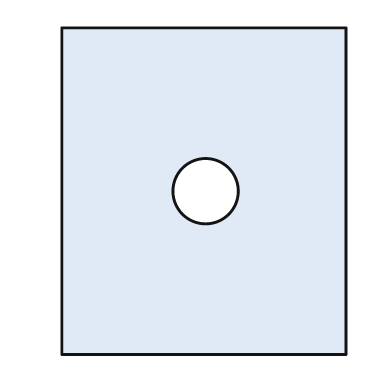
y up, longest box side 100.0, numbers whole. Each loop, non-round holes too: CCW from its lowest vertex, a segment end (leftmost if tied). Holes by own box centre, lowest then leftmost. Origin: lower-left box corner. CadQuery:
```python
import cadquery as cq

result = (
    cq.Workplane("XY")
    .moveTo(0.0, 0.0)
    .lineTo(87.0, 0.0)
    .lineTo(87.0, 100.0)
    .lineTo(0.0, 100.0)
    .close()
    .moveTo(44.0, 50.0)
    .circle(10.0)
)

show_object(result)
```